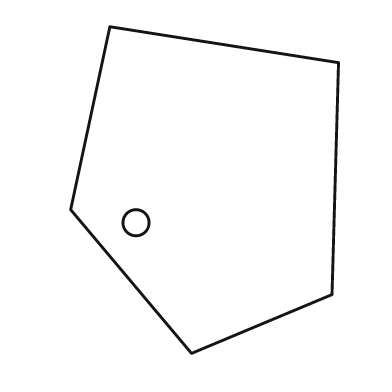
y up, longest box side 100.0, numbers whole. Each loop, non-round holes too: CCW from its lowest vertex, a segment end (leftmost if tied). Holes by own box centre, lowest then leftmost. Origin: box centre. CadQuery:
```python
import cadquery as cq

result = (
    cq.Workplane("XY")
    .moveTo(-4.0, -50.0)
    .lineTo(39.0, -32.0)
    .lineTo(41.0, 39.0)
    .lineTo(-29.0, 50.0)
    .lineTo(-41.0, -6.0)
    .close()
    .moveTo(-21.0, -10.0)
    .circle(4.0)
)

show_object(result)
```